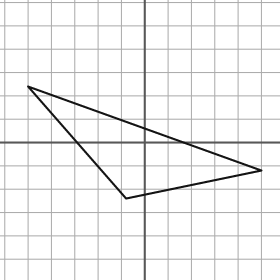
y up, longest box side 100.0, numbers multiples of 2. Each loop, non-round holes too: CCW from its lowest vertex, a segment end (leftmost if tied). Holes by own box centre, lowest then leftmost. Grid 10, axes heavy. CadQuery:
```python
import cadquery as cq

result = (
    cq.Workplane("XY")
    .moveTo(-8.0, -24.0)
    .lineTo(50.0, -12.0)
    .lineTo(-50.0, 24.0)
    .close()
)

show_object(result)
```